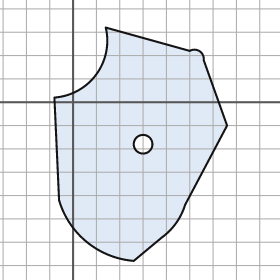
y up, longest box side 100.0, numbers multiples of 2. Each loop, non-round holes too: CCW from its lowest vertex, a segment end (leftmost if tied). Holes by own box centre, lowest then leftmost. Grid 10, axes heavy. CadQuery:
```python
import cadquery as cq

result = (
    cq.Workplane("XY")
    .moveTo(26.0, -68.0)
    .lineTo(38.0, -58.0)
    .threePointArc((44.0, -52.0), (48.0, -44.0))
    .lineTo(66.0, -10.0)
    .lineTo(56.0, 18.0)
    .threePointArc((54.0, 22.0), (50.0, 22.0))
    .lineTo(14.0, 32.0)
    .threePointArc((10.0, 12.0), (-8.0, 2.0))
    .lineTo(-6.0, -42.0)
    .threePointArc((6.0, -60.0), (26.0, -68.0))
    .close()
    .moveTo(30.0, -18.0)
    .circle(4.0)
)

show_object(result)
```